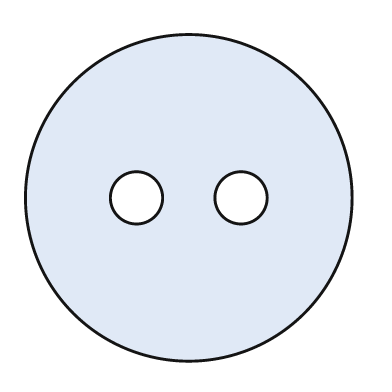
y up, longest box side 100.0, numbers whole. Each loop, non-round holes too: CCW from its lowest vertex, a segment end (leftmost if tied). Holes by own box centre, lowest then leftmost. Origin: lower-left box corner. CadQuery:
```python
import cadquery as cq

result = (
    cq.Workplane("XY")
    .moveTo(50.0, 50.0)
    .circle(50.0)
    .moveTo(34.0, 50.0)
    .circle(8.0)
    .moveTo(66.0, 50.0)
    .circle(8.0)
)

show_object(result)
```